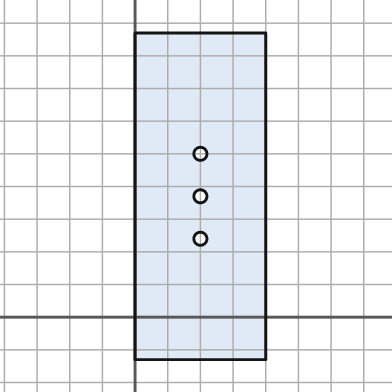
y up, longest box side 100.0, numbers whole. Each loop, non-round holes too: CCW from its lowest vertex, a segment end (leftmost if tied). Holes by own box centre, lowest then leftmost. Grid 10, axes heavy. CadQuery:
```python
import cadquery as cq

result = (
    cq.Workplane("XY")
    .moveTo(0.0, -13.0)
    .lineTo(40.0, -13.0)
    .lineTo(40.0, 87.0)
    .lineTo(0.0, 87.0)
    .close()
    .moveTo(20.0, 24.0)
    .circle(2.0)
    .moveTo(20.0, 37.0)
    .circle(2.0)
    .moveTo(20.0, 50.0)
    .circle(2.0)
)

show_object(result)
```